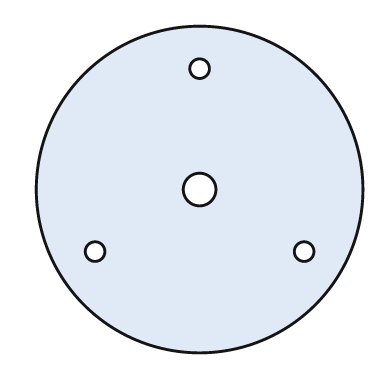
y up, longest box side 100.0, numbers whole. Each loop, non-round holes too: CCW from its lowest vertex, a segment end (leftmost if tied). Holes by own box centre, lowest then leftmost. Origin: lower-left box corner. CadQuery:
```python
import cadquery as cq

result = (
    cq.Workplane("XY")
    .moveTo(50.0, 50.0)
    .circle(50.0)
    .moveTo(18.0, 31.0)
    .circle(3.0)
    .moveTo(82.0, 31.0)
    .circle(3.0)
    .moveTo(50.0, 50.0)
    .circle(5.0)
    .moveTo(50.0, 87.0)
    .circle(3.0)
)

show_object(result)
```